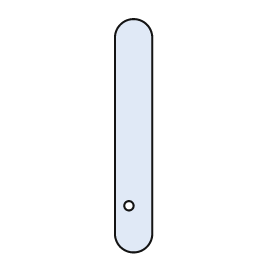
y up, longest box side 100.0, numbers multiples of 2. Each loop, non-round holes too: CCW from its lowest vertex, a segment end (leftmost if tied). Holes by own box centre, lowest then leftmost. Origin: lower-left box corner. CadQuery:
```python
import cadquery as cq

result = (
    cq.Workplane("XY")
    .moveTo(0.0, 8.0)
    .threePointArc((8.0, 0.0), (16.0, 8.0))
    .lineTo(16.0, 92.0)
    .threePointArc((8.0, 100.0), (0.0, 92.0))
    .close()
    .moveTo(6.0, 20.0)
    .circle(2.0)
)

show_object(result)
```